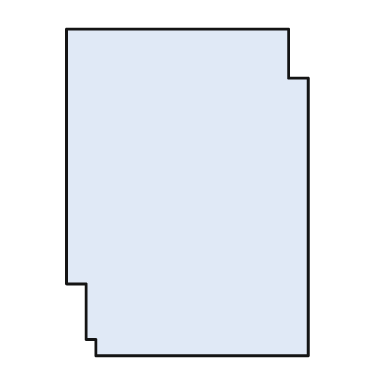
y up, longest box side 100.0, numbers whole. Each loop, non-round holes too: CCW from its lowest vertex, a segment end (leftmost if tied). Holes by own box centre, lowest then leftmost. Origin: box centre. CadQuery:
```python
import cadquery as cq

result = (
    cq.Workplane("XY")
    .moveTo(-28.0, -50.0)
    .lineTo(37.0, -50.0)
    .lineTo(37.0, 35.0)
    .lineTo(31.0, 35.0)
    .lineTo(31.0, 50.0)
    .lineTo(-37.0, 50.0)
    .lineTo(-37.0, -28.0)
    .lineTo(-31.0, -28.0)
    .lineTo(-31.0, -45.0)
    .lineTo(-28.0, -45.0)
    .close()
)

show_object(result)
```